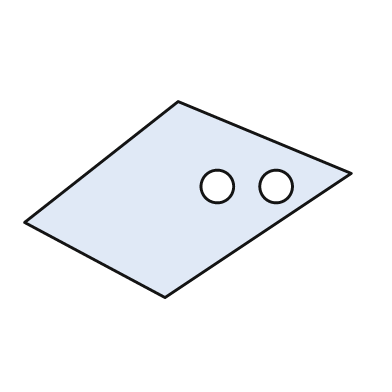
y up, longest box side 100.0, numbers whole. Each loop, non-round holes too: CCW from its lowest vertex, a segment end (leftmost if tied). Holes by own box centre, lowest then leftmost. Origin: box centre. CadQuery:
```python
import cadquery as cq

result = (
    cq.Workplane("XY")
    .moveTo(-7.0, -30.0)
    .lineTo(50.0, 8.0)
    .lineTo(-3.0, 30.0)
    .lineTo(-50.0, -7.0)
    .close()
    .moveTo(9.0, 4.0)
    .circle(5.0)
    .moveTo(27.0, 4.0)
    .circle(5.0)
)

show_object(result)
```